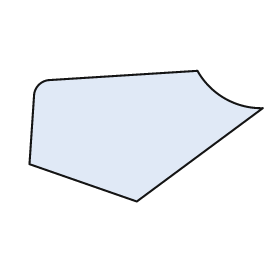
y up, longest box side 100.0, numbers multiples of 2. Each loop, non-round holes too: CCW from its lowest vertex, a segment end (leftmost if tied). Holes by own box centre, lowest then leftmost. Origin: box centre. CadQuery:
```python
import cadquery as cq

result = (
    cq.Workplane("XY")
    .moveTo(-4.0, -28.0)
    .lineTo(50.0, 12.0)
    .threePointArc((34.0, 16.0), (22.0, 28.0))
    .lineTo(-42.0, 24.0)
    .threePointArc((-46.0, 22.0), (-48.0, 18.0))
    .lineTo(-50.0, -12.0)
    .close()
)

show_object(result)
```